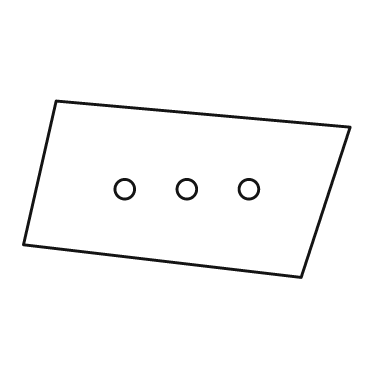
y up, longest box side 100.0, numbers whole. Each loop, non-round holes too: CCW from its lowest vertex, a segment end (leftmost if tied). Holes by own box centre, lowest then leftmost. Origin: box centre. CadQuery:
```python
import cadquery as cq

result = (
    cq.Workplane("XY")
    .moveTo(35.0, -27.0)
    .lineTo(50.0, 19.0)
    .lineTo(-40.0, 27.0)
    .lineTo(-50.0, -17.0)
    .close()
    .moveTo(-19.0, 0.0)
    .circle(3.0)
    .moveTo(0.0, 0.0)
    .circle(3.0)
    .moveTo(19.0, 0.0)
    .circle(3.0)
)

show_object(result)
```